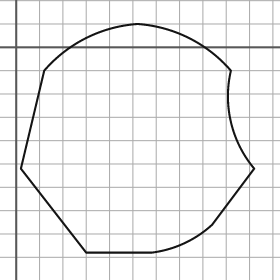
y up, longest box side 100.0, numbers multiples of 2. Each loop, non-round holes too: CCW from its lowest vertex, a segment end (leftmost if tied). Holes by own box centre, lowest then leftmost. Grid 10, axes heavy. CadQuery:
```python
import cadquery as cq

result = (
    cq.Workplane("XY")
    .moveTo(30.0, -88.0)
    .lineTo(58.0, -88.0)
    .threePointArc((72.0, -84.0), (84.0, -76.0))
    .lineTo(102.0, -52.0)
    .threePointArc((92.0, -32.0), (92.0, -10.0))
    .threePointArc((74.0, 4.0), (52.0, 10.0))
    .threePointArc((30.0, 4.0), (12.0, -10.0))
    .lineTo(2.0, -52.0)
    .close()
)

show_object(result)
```